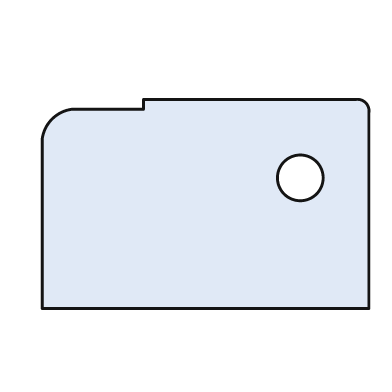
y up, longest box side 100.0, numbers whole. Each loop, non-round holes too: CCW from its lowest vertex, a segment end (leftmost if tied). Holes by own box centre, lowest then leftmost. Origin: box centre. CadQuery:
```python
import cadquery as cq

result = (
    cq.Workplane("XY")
    .moveTo(-50.0, -32.0)
    .lineTo(50.0, -32.0)
    .lineTo(50.0, 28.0)
    .threePointArc((49.0, 31.0), (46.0, 32.0))
    .lineTo(-19.0, 32.0)
    .lineTo(-19.0, 29.0)
    .lineTo(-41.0, 29.0)
    .threePointArc((-47.0, 26.0), (-50.0, 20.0))
    .close()
    .moveTo(29.0, 8.0)
    .circle(7.0)
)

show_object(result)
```